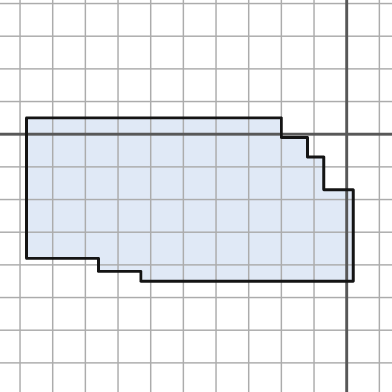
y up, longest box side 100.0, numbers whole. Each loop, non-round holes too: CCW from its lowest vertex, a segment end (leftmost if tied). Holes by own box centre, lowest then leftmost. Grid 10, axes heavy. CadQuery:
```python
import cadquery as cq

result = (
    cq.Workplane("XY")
    .moveTo(-63.0, -45.0)
    .lineTo(2.0, -45.0)
    .lineTo(2.0, -17.0)
    .lineTo(-7.0, -17.0)
    .lineTo(-7.0, -7.0)
    .lineTo(-12.0, -7.0)
    .lineTo(-12.0, -1.0)
    .lineTo(-20.0, -1.0)
    .lineTo(-20.0, 5.0)
    .lineTo(-98.0, 5.0)
    .lineTo(-98.0, -38.0)
    .lineTo(-76.0, -38.0)
    .lineTo(-76.0, -42.0)
    .lineTo(-63.0, -42.0)
    .close()
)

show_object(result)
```